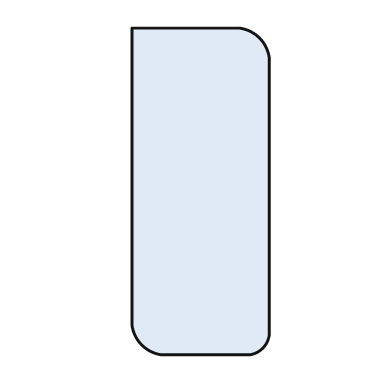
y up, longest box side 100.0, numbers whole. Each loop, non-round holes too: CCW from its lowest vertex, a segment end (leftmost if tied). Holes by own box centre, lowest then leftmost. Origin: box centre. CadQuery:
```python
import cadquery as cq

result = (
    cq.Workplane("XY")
    .moveTo(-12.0, -50.0)
    .lineTo(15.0, -50.0)
    .threePointArc((19.0, -48.0), (21.0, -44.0))
    .lineTo(21.0, 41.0)
    .threePointArc((18.0, 47.0), (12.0, 50.0))
    .lineTo(-21.0, 50.0)
    .lineTo(-21.0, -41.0)
    .threePointArc((-18.0, -47.0), (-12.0, -50.0))
    .close()
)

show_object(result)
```